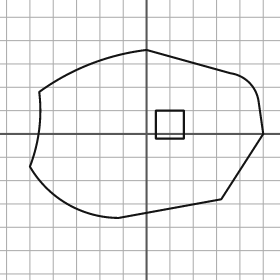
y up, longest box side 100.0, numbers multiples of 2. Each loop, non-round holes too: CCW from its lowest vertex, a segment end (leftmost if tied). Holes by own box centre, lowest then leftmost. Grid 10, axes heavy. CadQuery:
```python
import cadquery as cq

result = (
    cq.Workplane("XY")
    .moveTo(-12.0, -36.0)
    .lineTo(32.0, -28.0)
    .lineTo(50.0, 0.0)
    .lineTo(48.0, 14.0)
    .threePointArc((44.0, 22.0), (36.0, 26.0))
    .lineTo(0.0, 36.0)
    .threePointArc((-24.0, 30.0), (-46.0, 18.0))
    .threePointArc((-46.0, 2.0), (-50.0, -14.0))
    .threePointArc((-34.0, -30.0), (-12.0, -36.0))
    .close()
    .moveTo(4.0, -2.0)
    .lineTo(16.0, -2.0)
    .lineTo(16.0, 10.0)
    .lineTo(4.0, 10.0)
    .close()
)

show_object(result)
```